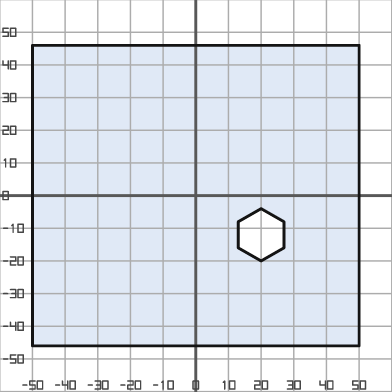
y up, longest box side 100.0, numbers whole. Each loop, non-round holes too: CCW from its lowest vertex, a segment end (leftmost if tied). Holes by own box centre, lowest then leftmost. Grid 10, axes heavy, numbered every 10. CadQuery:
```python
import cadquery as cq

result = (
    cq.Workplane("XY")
    .moveTo(-50.0, -46.0)
    .lineTo(50.0, -46.0)
    .lineTo(50.0, 46.0)
    .lineTo(-50.0, 46.0)
    .close()
    .moveTo(20.0, -20.0)
    .lineTo(27.0, -16.0)
    .lineTo(27.0, -8.0)
    .lineTo(20.0, -4.0)
    .lineTo(13.0, -8.0)
    .lineTo(13.0, -16.0)
    .close()
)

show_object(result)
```